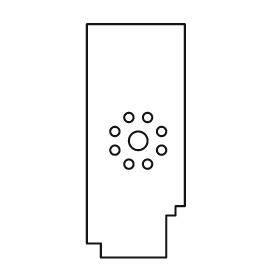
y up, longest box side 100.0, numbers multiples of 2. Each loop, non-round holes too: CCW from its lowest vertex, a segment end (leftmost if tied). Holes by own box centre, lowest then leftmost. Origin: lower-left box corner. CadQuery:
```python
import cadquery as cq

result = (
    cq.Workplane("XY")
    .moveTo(6.0, 0.0)
    .lineTo(34.0, 0.0)
    .lineTo(34.0, 18.0)
    .lineTo(38.0, 18.0)
    .lineTo(38.0, 22.0)
    .lineTo(42.0, 22.0)
    .lineTo(42.0, 100.0)
    .lineTo(0.0, 100.0)
    .lineTo(0.0, 6.0)
    .lineTo(6.0, 6.0)
    .close()
    .moveTo(18.0, 40.0)
    .circle(2.0)
    .moveTo(26.0, 40.0)
    .circle(2.0)
    .moveTo(12.0, 46.0)
    .circle(2.0)
    .moveTo(32.0, 46.0)
    .circle(2.0)
    .moveTo(22.0, 50.0)
    .circle(4.0)
    .moveTo(12.0, 54.0)
    .circle(2.0)
    .moveTo(32.0, 54.0)
    .circle(2.0)
    .moveTo(18.0, 60.0)
    .circle(2.0)
    .moveTo(26.0, 60.0)
    .circle(2.0)
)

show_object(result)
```